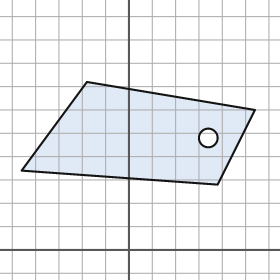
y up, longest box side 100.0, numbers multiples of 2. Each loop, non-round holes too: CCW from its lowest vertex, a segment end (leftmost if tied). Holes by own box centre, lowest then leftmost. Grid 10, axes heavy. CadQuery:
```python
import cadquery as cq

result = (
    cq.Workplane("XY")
    .moveTo(38.0, 28.0)
    .lineTo(54.0, 60.0)
    .lineTo(-18.0, 72.0)
    .lineTo(-46.0, 34.0)
    .close()
    .moveTo(34.0, 48.0)
    .circle(4.0)
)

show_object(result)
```